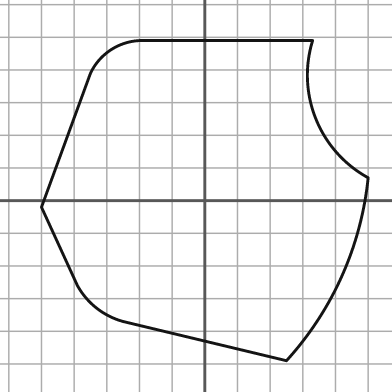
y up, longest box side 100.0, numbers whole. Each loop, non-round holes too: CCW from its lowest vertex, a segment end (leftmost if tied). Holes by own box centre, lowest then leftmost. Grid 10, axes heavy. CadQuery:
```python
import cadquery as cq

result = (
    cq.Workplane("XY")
    .moveTo(25.0, -49.0)
    .threePointArc((42.0, -23.0), (50.0, 7.0))
    .threePointArc((34.0, 25.0), (33.0, 49.0))
    .lineTo(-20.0, 49.0)
    .threePointArc((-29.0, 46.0), (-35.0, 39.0))
    .lineTo(-50.0, -2.0)
    .lineTo(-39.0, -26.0)
    .threePointArc((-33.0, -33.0), (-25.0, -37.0))
    .close()
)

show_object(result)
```